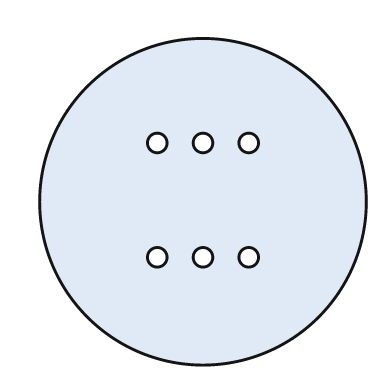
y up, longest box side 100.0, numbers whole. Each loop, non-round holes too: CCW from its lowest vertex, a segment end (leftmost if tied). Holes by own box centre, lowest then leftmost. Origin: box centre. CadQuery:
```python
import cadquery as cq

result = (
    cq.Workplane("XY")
    .moveTo(0.0, 0.0)
    .circle(50.0)
    .moveTo(-14.0, -17.0)
    .circle(3.0)
    .moveTo(0.0, -17.0)
    .circle(3.0)
    .moveTo(14.0, -17.0)
    .circle(3.0)
    .moveTo(-14.0, 18.0)
    .circle(3.0)
    .moveTo(0.0, 18.0)
    .circle(3.0)
    .moveTo(14.0, 18.0)
    .circle(3.0)
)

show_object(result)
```